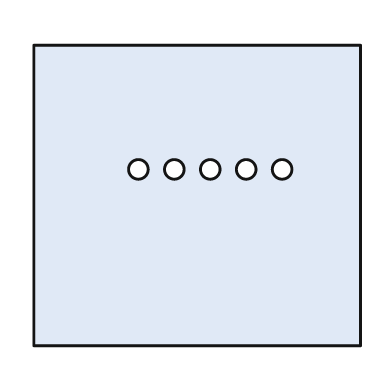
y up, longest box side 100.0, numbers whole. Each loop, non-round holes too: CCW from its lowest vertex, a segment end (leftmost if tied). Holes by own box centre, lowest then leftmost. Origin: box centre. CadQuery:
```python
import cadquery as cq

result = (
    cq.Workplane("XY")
    .moveTo(-50.0, -46.0)
    .lineTo(50.0, -46.0)
    .lineTo(50.0, 46.0)
    .lineTo(-50.0, 46.0)
    .close()
    .moveTo(-18.0, 8.0)
    .circle(3.0)
    .moveTo(-7.0, 8.0)
    .circle(3.0)
    .moveTo(4.0, 8.0)
    .circle(3.0)
    .moveTo(15.0, 8.0)
    .circle(3.0)
    .moveTo(26.0, 8.0)
    .circle(3.0)
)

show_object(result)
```